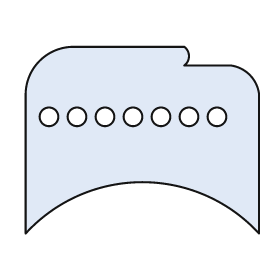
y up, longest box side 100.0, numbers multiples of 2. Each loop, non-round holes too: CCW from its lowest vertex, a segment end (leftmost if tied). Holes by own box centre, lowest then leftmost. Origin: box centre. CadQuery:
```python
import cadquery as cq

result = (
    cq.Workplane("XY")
    .moveTo(-50.0, -40.0)
    .threePointArc((0.0, -18.0), (50.0, -40.0))
    .lineTo(50.0, 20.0)
    .threePointArc((46.0, 28.0), (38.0, 32.0))
    .lineTo(18.0, 32.0)
    .threePointArc((20.0, 36.0), (18.0, 40.0))
    .lineTo(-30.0, 40.0)
    .threePointArc((-44.0, 34.0), (-50.0, 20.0))
    .close()
    .moveTo(-40.0, 10.0)
    .circle(4.0)
    .moveTo(-28.0, 10.0)
    .circle(4.0)
    .moveTo(-16.0, 10.0)
    .circle(4.0)
    .moveTo(-4.0, 10.0)
    .circle(4.0)
    .moveTo(8.0, 10.0)
    .circle(4.0)
    .moveTo(20.0, 10.0)
    .circle(4.0)
    .moveTo(32.0, 10.0)
    .circle(4.0)
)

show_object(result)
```